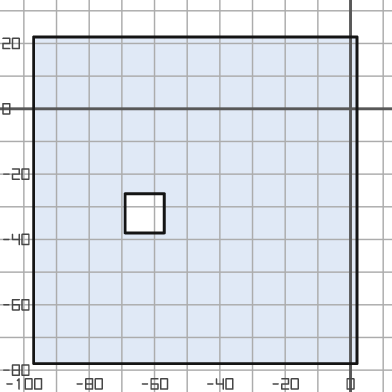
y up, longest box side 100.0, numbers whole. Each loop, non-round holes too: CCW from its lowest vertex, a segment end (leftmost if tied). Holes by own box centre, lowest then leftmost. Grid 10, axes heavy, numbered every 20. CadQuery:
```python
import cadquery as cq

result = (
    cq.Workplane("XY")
    .moveTo(-97.0, -78.0)
    .lineTo(2.0, -78.0)
    .lineTo(2.0, 22.0)
    .lineTo(-97.0, 22.0)
    .close()
    .moveTo(-69.0, -38.0)
    .lineTo(-57.0, -38.0)
    .lineTo(-57.0, -26.0)
    .lineTo(-69.0, -26.0)
    .close()
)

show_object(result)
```